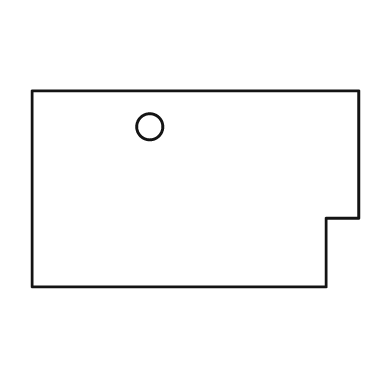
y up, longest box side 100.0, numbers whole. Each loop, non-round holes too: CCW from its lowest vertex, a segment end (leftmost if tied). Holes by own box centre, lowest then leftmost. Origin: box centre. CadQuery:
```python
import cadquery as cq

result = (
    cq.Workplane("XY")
    .moveTo(-50.0, -30.0)
    .lineTo(40.0, -30.0)
    .lineTo(40.0, -9.0)
    .lineTo(50.0, -9.0)
    .lineTo(50.0, 30.0)
    .lineTo(-50.0, 30.0)
    .close()
    .moveTo(-14.0, 19.0)
    .circle(4.0)
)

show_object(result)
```